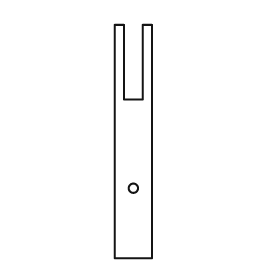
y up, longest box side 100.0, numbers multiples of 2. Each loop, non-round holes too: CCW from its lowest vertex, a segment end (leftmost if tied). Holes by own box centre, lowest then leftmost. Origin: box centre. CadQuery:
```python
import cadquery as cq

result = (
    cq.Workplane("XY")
    .moveTo(-8.0, -50.0)
    .lineTo(8.0, -50.0)
    .lineTo(8.0, 50.0)
    .lineTo(4.0, 50.0)
    .lineTo(4.0, 18.0)
    .lineTo(-4.0, 18.0)
    .lineTo(-4.0, 50.0)
    .lineTo(-8.0, 50.0)
    .close()
    .moveTo(0.0, -20.0)
    .circle(2.0)
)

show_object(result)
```